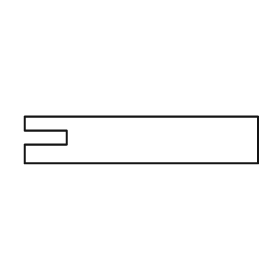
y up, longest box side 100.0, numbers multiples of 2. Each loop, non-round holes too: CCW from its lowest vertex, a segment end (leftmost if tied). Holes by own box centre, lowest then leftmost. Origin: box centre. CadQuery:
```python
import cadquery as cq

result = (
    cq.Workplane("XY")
    .moveTo(-50.0, -10.0)
    .lineTo(50.0, -10.0)
    .lineTo(50.0, 10.0)
    .lineTo(-50.0, 10.0)
    .lineTo(-50.0, 4.0)
    .lineTo(-32.0, 4.0)
    .lineTo(-32.0, -2.0)
    .lineTo(-50.0, -2.0)
    .close()
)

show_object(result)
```